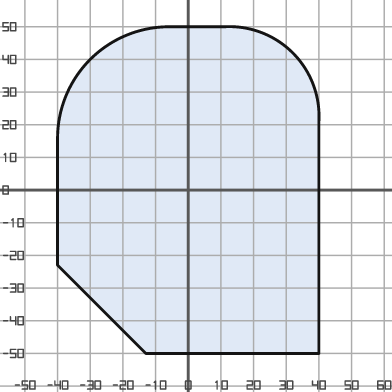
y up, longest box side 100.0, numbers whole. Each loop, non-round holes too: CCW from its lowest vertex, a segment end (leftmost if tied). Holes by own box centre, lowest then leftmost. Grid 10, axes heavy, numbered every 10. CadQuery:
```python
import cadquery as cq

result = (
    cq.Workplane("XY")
    .moveTo(-13.0, -50.0)
    .lineTo(40.0, -50.0)
    .lineTo(40.0, 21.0)
    .threePointArc((32.0, 42.0), (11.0, 50.0))
    .lineTo(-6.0, 50.0)
    .threePointArc((-30.0, 40.0), (-40.0, 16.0))
    .lineTo(-40.0, -23.0)
    .close()
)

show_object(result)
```